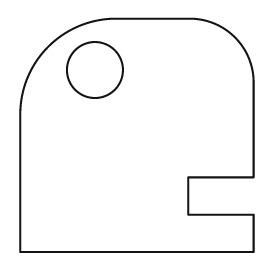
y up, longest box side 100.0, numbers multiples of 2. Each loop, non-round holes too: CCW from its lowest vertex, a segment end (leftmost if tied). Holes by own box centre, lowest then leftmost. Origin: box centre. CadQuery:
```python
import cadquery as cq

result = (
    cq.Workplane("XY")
    .moveTo(-50.0, -50.0)
    .lineTo(50.0, -50.0)
    .lineTo(50.0, -34.0)
    .lineTo(22.0, -34.0)
    .lineTo(22.0, -18.0)
    .lineTo(50.0, -18.0)
    .lineTo(50.0, 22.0)
    .threePointArc((42.0, 42.0), (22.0, 50.0))
    .lineTo(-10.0, 50.0)
    .threePointArc((-38.0, 38.0), (-50.0, 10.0))
    .close()
    .moveTo(-18.0, 28.0)
    .circle(12.0)
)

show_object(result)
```